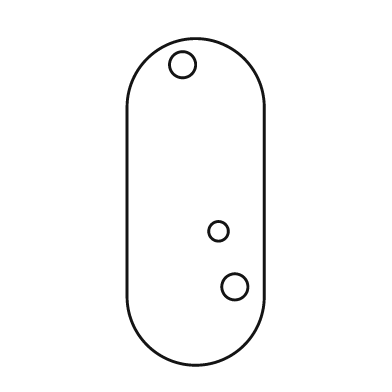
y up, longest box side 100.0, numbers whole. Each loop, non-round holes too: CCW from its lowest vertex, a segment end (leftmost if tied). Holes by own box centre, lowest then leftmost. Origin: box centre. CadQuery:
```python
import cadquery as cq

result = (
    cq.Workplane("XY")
    .moveTo(-21.0, -29.0)
    .threePointArc((0.0, -50.0), (21.0, -29.0))
    .lineTo(21.0, 29.0)
    .threePointArc((0.0, 50.0), (-21.0, 29.0))
    .close()
    .moveTo(12.0, -26.0)
    .circle(4.0)
    .moveTo(7.0, -9.0)
    .circle(3.0)
    .moveTo(-4.0, 42.0)
    .circle(4.0)
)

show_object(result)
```